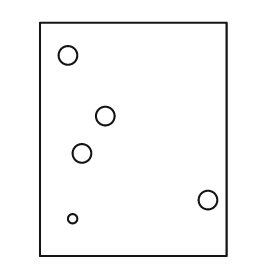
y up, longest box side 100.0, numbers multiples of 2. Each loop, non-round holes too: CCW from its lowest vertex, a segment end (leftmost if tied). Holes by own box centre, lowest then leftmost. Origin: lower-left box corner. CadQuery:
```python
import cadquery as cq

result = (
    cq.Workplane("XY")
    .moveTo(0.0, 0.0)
    .lineTo(80.0, 0.0)
    .lineTo(80.0, 100.0)
    .lineTo(0.0, 100.0)
    .close()
    .moveTo(14.0, 16.0)
    .circle(2.0)
    .moveTo(72.0, 24.0)
    .circle(4.0)
    .moveTo(18.0, 44.0)
    .circle(4.0)
    .moveTo(28.0, 60.0)
    .circle(4.0)
    .moveTo(12.0, 86.0)
    .circle(4.0)
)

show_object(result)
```